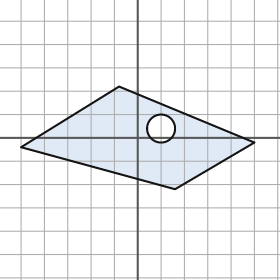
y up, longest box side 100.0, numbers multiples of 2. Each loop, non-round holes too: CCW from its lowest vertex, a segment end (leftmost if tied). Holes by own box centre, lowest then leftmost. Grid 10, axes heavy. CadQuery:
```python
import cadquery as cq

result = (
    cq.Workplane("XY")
    .moveTo(16.0, -22.0)
    .lineTo(50.0, -2.0)
    .lineTo(-8.0, 22.0)
    .lineTo(-50.0, -4.0)
    .close()
    .moveTo(10.0, 4.0)
    .circle(6.0)
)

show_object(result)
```